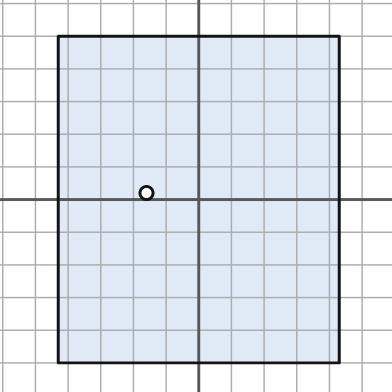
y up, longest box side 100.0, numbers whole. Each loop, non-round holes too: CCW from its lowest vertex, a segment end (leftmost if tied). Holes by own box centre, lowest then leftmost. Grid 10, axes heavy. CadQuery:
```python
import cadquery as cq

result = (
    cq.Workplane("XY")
    .moveTo(-43.0, -50.0)
    .lineTo(43.0, -50.0)
    .lineTo(43.0, 50.0)
    .lineTo(-43.0, 50.0)
    .close()
    .moveTo(-16.0, 2.0)
    .circle(2.0)
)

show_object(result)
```